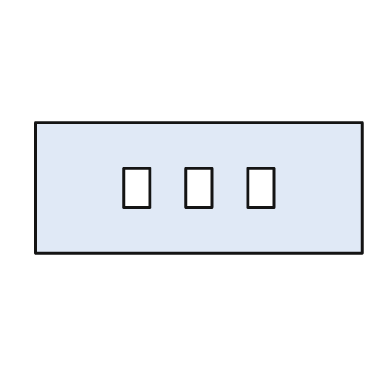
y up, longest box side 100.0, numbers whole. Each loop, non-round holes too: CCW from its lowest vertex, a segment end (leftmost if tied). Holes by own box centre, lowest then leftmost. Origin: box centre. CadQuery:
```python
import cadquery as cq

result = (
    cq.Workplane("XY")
    .moveTo(-50.0, -20.0)
    .lineTo(50.0, -20.0)
    .lineTo(50.0, 20.0)
    .lineTo(-50.0, 20.0)
    .close()
    .moveTo(-23.0, -6.0)
    .lineTo(-15.0, -6.0)
    .lineTo(-15.0, 6.0)
    .lineTo(-23.0, 6.0)
    .close()
    .moveTo(-4.0, -6.0)
    .lineTo(4.0, -6.0)
    .lineTo(4.0, 6.0)
    .lineTo(-4.0, 6.0)
    .close()
    .moveTo(15.0, -6.0)
    .lineTo(23.0, -6.0)
    .lineTo(23.0, 6.0)
    .lineTo(15.0, 6.0)
    .close()
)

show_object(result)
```